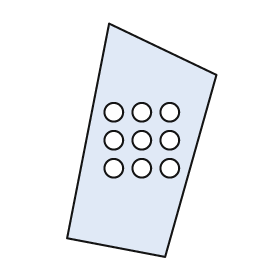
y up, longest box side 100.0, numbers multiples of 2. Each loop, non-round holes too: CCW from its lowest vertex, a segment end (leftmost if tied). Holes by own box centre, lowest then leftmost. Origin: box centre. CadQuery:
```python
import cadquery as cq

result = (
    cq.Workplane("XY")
    .moveTo(10.0, -50.0)
    .lineTo(32.0, 28.0)
    .lineTo(-14.0, 50.0)
    .lineTo(-32.0, -42.0)
    .close()
    .moveTo(-12.0, -12.0)
    .circle(4.0)
    .moveTo(0.0, -12.0)
    .circle(4.0)
    .moveTo(12.0, -12.0)
    .circle(4.0)
    .moveTo(-12.0, 0.0)
    .circle(4.0)
    .moveTo(0.0, 0.0)
    .circle(4.0)
    .moveTo(12.0, 0.0)
    .circle(4.0)
    .moveTo(-12.0, 12.0)
    .circle(4.0)
    .moveTo(0.0, 12.0)
    .circle(4.0)
    .moveTo(12.0, 12.0)
    .circle(4.0)
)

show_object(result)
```